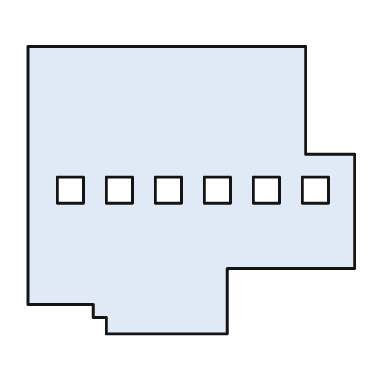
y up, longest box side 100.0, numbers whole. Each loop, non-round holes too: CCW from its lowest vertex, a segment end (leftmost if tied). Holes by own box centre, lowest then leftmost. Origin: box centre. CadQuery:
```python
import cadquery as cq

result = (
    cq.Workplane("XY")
    .moveTo(-26.0, -44.0)
    .lineTo(11.0, -44.0)
    .lineTo(11.0, -24.0)
    .lineTo(50.0, -24.0)
    .lineTo(50.0, 11.0)
    .lineTo(35.0, 11.0)
    .lineTo(35.0, 44.0)
    .lineTo(-50.0, 44.0)
    .lineTo(-50.0, -35.0)
    .lineTo(-30.0, -35.0)
    .lineTo(-30.0, -39.0)
    .lineTo(-26.0, -39.0)
    .close()
    .moveTo(-41.0, -4.0)
    .lineTo(-33.0, -4.0)
    .lineTo(-33.0, 4.0)
    .lineTo(-41.0, 4.0)
    .close()
    .moveTo(-26.0, -4.0)
    .lineTo(-18.0, -4.0)
    .lineTo(-18.0, 4.0)
    .lineTo(-26.0, 4.0)
    .close()
    .moveTo(-11.0, -4.0)
    .lineTo(-3.0, -4.0)
    .lineTo(-3.0, 4.0)
    .lineTo(-11.0, 4.0)
    .close()
    .moveTo(4.0, -4.0)
    .lineTo(12.0, -4.0)
    .lineTo(12.0, 4.0)
    .lineTo(4.0, 4.0)
    .close()
    .moveTo(19.0, -4.0)
    .lineTo(27.0, -4.0)
    .lineTo(27.0, 4.0)
    .lineTo(19.0, 4.0)
    .close()
    .moveTo(34.0, -4.0)
    .lineTo(42.0, -4.0)
    .lineTo(42.0, 4.0)
    .lineTo(34.0, 4.0)
    .close()
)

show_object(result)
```